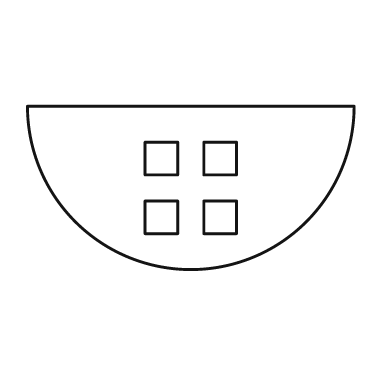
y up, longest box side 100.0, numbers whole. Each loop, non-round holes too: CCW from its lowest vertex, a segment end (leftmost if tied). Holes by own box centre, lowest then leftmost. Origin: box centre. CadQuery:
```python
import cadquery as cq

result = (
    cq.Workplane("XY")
    .moveTo(-50.0, 25.0)
    .threePointArc((0.0, -25.0), (50.0, 25.0))
    .close()
    .moveTo(-14.0, -14.0)
    .lineTo(-4.0, -14.0)
    .lineTo(-4.0, -4.0)
    .lineTo(-14.0, -4.0)
    .close()
    .moveTo(4.0, -14.0)
    .lineTo(14.0, -14.0)
    .lineTo(14.0, -4.0)
    .lineTo(4.0, -4.0)
    .close()
    .moveTo(-14.0, 4.0)
    .lineTo(-4.0, 4.0)
    .lineTo(-4.0, 14.0)
    .lineTo(-14.0, 14.0)
    .close()
    .moveTo(4.0, 4.0)
    .lineTo(14.0, 4.0)
    .lineTo(14.0, 14.0)
    .lineTo(4.0, 14.0)
    .close()
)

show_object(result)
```